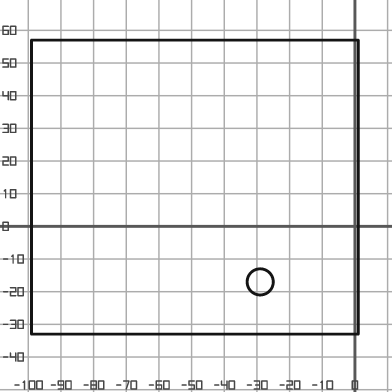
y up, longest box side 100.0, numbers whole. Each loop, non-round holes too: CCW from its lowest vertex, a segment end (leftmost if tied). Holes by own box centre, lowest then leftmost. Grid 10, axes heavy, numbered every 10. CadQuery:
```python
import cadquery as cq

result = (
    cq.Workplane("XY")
    .moveTo(-99.0, -33.0)
    .lineTo(1.0, -33.0)
    .lineTo(1.0, 57.0)
    .lineTo(-99.0, 57.0)
    .close()
    .moveTo(-29.0, -17.0)
    .circle(4.0)
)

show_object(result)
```